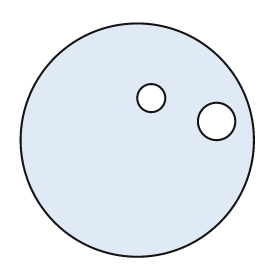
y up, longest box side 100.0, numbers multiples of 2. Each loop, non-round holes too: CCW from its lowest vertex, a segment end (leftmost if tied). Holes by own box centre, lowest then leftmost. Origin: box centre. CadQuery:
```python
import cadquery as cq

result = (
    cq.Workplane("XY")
    .moveTo(0.0, 0.0)
    .circle(50.0)
    .moveTo(34.0, 8.0)
    .circle(8.0)
    .moveTo(6.0, 18.0)
    .circle(6.0)
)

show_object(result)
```